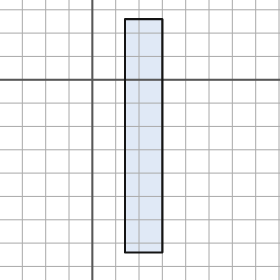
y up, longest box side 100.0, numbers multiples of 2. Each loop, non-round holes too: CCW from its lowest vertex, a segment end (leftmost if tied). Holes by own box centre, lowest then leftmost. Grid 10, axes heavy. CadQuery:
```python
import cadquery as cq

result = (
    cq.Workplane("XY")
    .moveTo(14.0, -74.0)
    .lineTo(30.0, -74.0)
    .lineTo(30.0, 26.0)
    .lineTo(14.0, 26.0)
    .close()
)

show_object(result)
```